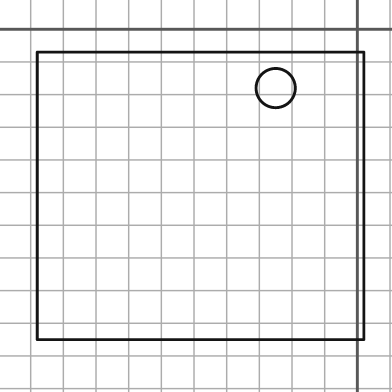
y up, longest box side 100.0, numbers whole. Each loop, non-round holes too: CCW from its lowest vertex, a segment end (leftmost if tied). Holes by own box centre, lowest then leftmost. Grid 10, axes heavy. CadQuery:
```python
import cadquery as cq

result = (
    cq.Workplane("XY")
    .moveTo(-98.0, -95.0)
    .lineTo(2.0, -95.0)
    .lineTo(2.0, -7.0)
    .lineTo(-98.0, -7.0)
    .close()
    .moveTo(-25.0, -18.0)
    .circle(6.0)
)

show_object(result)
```